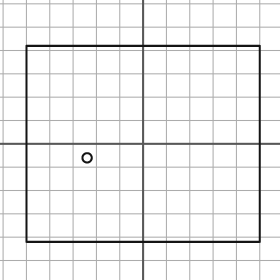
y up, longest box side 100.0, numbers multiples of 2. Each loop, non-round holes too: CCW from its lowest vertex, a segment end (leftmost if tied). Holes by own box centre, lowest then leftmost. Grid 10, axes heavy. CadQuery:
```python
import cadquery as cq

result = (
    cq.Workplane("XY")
    .moveTo(-50.0, -42.0)
    .lineTo(50.0, -42.0)
    .lineTo(50.0, 42.0)
    .lineTo(-50.0, 42.0)
    .close()
    .moveTo(-24.0, -6.0)
    .circle(2.0)
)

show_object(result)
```